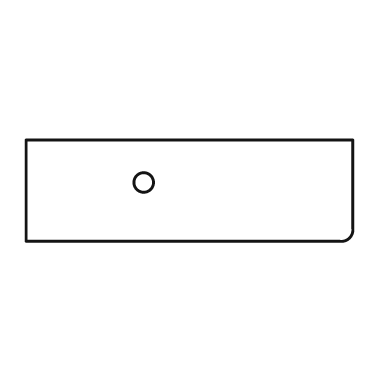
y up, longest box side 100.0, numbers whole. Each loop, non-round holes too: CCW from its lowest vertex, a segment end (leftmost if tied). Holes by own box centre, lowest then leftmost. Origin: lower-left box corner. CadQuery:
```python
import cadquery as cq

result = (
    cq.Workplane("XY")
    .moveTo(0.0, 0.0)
    .lineTo(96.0, 0.0)
    .threePointArc((99.0, 1.0), (100.0, 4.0))
    .lineTo(100.0, 31.0)
    .lineTo(0.0, 31.0)
    .close()
    .moveTo(36.0, 18.0)
    .circle(3.0)
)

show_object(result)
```